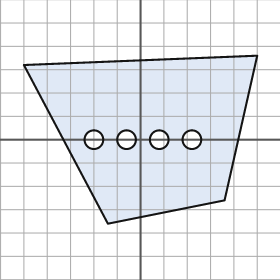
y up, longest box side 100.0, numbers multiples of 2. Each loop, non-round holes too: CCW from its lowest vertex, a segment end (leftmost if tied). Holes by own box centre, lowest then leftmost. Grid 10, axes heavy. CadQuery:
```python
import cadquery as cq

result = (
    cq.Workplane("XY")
    .moveTo(-14.0, -36.0)
    .lineTo(36.0, -26.0)
    .lineTo(50.0, 36.0)
    .lineTo(-50.0, 32.0)
    .close()
    .moveTo(-20.0, 0.0)
    .circle(4.0)
    .moveTo(-6.0, 0.0)
    .circle(4.0)
    .moveTo(8.0, 0.0)
    .circle(4.0)
    .moveTo(22.0, 0.0)
    .circle(4.0)
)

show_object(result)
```